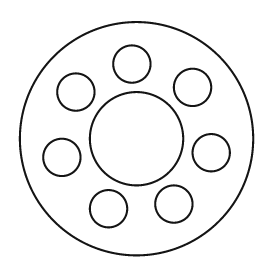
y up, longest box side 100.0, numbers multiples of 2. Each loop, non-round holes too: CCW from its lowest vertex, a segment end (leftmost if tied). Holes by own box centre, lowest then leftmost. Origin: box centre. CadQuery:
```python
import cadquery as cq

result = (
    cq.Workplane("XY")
    .moveTo(0.0, 0.0)
    .circle(50.0)
    .moveTo(-12.0, -30.0)
    .circle(8.0)
    .moveTo(16.0, -28.0)
    .circle(8.0)
    .moveTo(-32.0, -8.0)
    .circle(8.0)
    .moveTo(32.0, -6.0)
    .circle(8.0)
    .moveTo(0.0, 0.0)
    .circle(20.0)
    .moveTo(-26.0, 20.0)
    .circle(8.0)
    .moveTo(24.0, 22.0)
    .circle(8.0)
    .moveTo(-2.0, 32.0)
    .circle(8.0)
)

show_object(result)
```